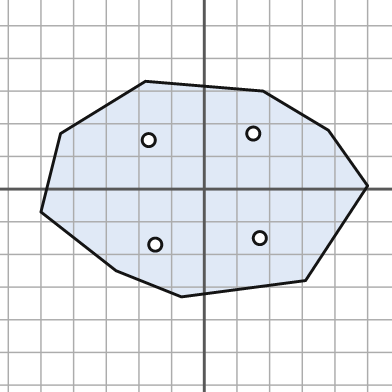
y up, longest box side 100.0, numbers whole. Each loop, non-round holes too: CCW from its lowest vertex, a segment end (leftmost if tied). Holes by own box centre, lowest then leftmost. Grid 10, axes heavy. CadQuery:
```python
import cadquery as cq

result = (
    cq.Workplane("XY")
    .moveTo(-7.0, -33.0)
    .lineTo(31.0, -28.0)
    .lineTo(50.0, 1.0)
    .lineTo(38.0, 18.0)
    .lineTo(18.0, 30.0)
    .lineTo(-18.0, 33.0)
    .lineTo(-44.0, 17.0)
    .lineTo(-50.0, -7.0)
    .lineTo(-27.0, -25.0)
    .close()
    .moveTo(-15.0, -17.0)
    .circle(2.0)
    .moveTo(17.0, -15.0)
    .circle(2.0)
    .moveTo(-17.0, 15.0)
    .circle(2.0)
    .moveTo(15.0, 17.0)
    .circle(2.0)
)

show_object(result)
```